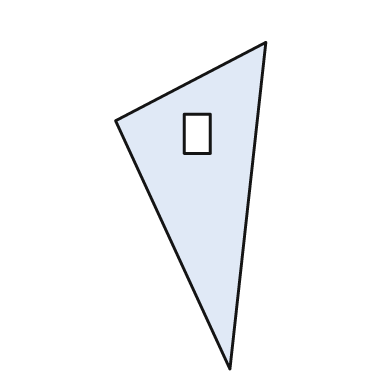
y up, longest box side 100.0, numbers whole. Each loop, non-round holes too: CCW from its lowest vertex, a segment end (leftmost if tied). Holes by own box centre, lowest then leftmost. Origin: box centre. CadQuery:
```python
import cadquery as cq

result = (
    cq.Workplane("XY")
    .moveTo(12.0, -50.0)
    .lineTo(23.0, 50.0)
    .lineTo(-23.0, 26.0)
    .close()
    .moveTo(-2.0, 16.0)
    .lineTo(6.0, 16.0)
    .lineTo(6.0, 28.0)
    .lineTo(-2.0, 28.0)
    .close()
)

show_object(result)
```